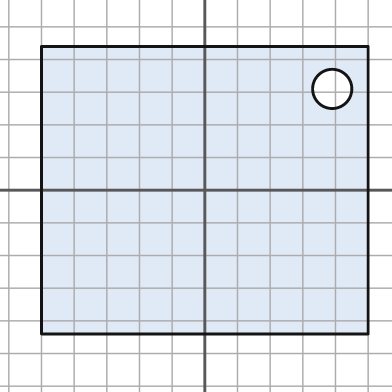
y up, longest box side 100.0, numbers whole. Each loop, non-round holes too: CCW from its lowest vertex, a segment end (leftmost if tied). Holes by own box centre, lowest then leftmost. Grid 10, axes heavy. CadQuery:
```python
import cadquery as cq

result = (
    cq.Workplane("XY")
    .moveTo(-50.0, -44.0)
    .lineTo(50.0, -44.0)
    .lineTo(50.0, 44.0)
    .lineTo(-50.0, 44.0)
    .close()
    .moveTo(39.0, 31.0)
    .circle(6.0)
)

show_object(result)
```